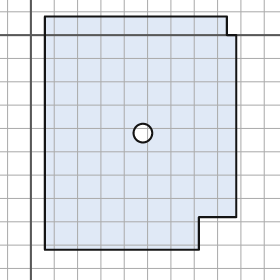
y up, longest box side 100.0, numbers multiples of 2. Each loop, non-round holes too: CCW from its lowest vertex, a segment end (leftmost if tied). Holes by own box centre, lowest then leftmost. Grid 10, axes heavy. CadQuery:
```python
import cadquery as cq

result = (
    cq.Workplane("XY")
    .moveTo(6.0, -92.0)
    .lineTo(72.0, -92.0)
    .lineTo(72.0, -78.0)
    .lineTo(88.0, -78.0)
    .lineTo(88.0, 0.0)
    .lineTo(84.0, 0.0)
    .lineTo(84.0, 8.0)
    .lineTo(6.0, 8.0)
    .close()
    .moveTo(48.0, -42.0)
    .circle(4.0)
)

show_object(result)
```